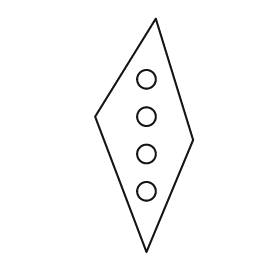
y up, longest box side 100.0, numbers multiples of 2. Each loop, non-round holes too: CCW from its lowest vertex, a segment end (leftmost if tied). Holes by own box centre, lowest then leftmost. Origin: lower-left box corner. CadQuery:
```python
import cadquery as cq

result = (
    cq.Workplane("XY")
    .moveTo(22.0, 0.0)
    .lineTo(42.0, 48.0)
    .lineTo(26.0, 100.0)
    .lineTo(0.0, 58.0)
    .close()
    .moveTo(22.0, 26.0)
    .circle(4.0)
    .moveTo(22.0, 42.0)
    .circle(4.0)
    .moveTo(22.0, 58.0)
    .circle(4.0)
    .moveTo(22.0, 74.0)
    .circle(4.0)
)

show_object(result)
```